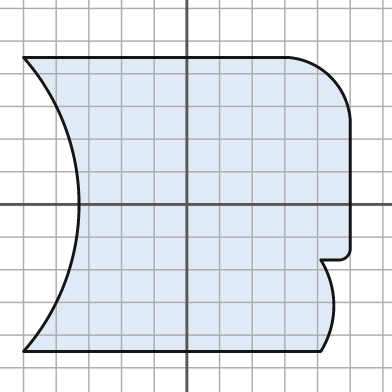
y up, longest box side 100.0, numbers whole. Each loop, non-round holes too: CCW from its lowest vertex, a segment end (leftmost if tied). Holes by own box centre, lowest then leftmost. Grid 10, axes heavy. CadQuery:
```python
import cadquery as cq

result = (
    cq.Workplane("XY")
    .moveTo(-50.0, -45.0)
    .lineTo(41.0, -45.0)
    .threePointArc((45.0, -31.0), (41.0, -17.0))
    .lineTo(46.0, -17.0)
    .threePointArc((49.0, -16.0), (50.0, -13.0))
    .lineTo(50.0, 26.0)
    .threePointArc((44.0, 39.0), (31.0, 45.0))
    .lineTo(-50.0, 45.0)
    .threePointArc((-33.0, 0.0), (-50.0, -45.0))
    .close()
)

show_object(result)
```